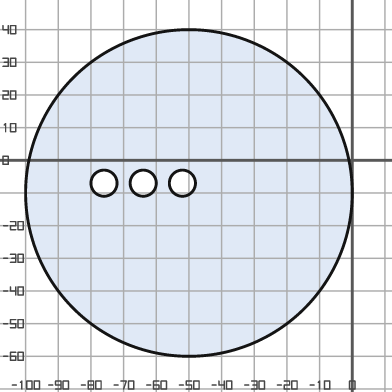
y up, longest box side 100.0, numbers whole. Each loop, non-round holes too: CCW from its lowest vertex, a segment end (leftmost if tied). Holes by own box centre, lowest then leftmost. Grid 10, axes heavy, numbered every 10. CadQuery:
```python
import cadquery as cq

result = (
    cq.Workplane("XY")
    .moveTo(-50.0, -10.0)
    .circle(50.0)
    .moveTo(-76.0, -7.0)
    .circle(4.0)
    .moveTo(-64.0, -7.0)
    .circle(4.0)
    .moveTo(-52.0, -7.0)
    .circle(4.0)
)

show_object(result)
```